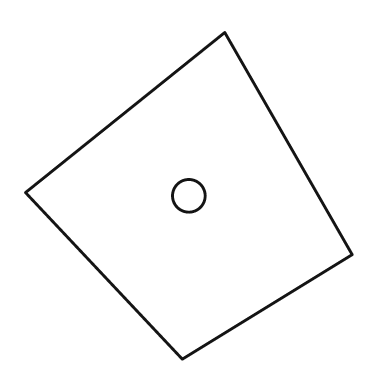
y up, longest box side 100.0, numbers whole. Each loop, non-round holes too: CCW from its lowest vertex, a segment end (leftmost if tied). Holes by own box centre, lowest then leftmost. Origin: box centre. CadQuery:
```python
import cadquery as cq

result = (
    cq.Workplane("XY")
    .moveTo(-2.0, -50.0)
    .lineTo(50.0, -18.0)
    .lineTo(11.0, 50.0)
    .lineTo(-50.0, 1.0)
    .close()
    .moveTo(0.0, 0.0)
    .circle(5.0)
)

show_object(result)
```